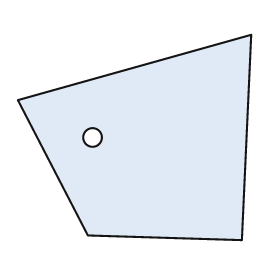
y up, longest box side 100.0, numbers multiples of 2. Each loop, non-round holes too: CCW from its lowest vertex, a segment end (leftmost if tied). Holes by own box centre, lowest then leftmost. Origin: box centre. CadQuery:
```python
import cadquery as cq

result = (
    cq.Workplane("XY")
    .moveTo(46.0, -44.0)
    .lineTo(50.0, 44.0)
    .lineTo(-50.0, 16.0)
    .lineTo(-20.0, -42.0)
    .close()
    .moveTo(-18.0, 0.0)
    .circle(4.0)
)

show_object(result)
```